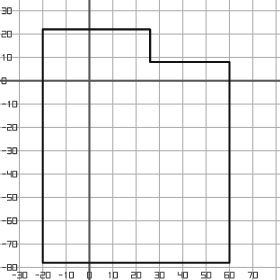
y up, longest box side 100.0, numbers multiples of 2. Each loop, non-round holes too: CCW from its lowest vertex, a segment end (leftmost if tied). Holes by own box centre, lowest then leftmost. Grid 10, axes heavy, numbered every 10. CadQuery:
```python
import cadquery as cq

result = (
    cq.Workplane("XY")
    .moveTo(-20.0, -78.0)
    .lineTo(60.0, -78.0)
    .lineTo(60.0, 8.0)
    .lineTo(26.0, 8.0)
    .lineTo(26.0, 22.0)
    .lineTo(-20.0, 22.0)
    .close()
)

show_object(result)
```